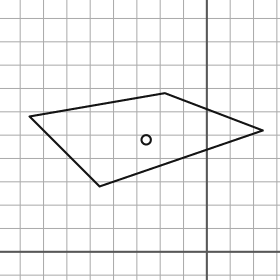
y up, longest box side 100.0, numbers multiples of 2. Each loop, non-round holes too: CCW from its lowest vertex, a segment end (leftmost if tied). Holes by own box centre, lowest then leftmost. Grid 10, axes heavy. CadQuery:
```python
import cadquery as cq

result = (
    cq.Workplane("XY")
    .moveTo(-46.0, 28.0)
    .lineTo(24.0, 52.0)
    .lineTo(-18.0, 68.0)
    .lineTo(-76.0, 58.0)
    .close()
    .moveTo(-26.0, 48.0)
    .circle(2.0)
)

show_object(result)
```